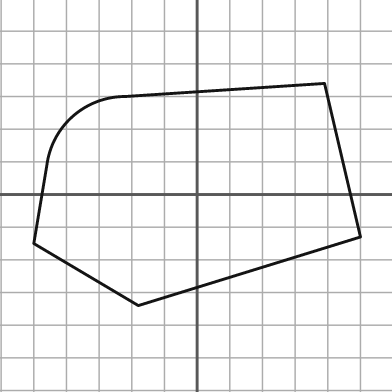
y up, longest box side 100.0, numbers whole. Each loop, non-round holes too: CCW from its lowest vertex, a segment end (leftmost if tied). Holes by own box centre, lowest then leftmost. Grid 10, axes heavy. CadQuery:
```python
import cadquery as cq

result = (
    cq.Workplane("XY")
    .moveTo(-18.0, -34.0)
    .lineTo(50.0, -13.0)
    .lineTo(39.0, 34.0)
    .lineTo(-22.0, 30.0)
    .threePointArc((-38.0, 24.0), (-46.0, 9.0))
    .lineTo(-50.0, -15.0)
    .close()
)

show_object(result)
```